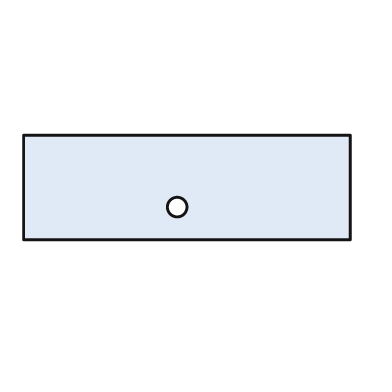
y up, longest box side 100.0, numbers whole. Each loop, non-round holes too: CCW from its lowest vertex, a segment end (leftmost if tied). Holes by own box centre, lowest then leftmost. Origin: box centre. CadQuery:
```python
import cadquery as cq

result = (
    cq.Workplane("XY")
    .moveTo(-50.0, -16.0)
    .lineTo(50.0, -16.0)
    .lineTo(50.0, 16.0)
    .lineTo(-50.0, 16.0)
    .close()
    .moveTo(-3.0, -6.0)
    .circle(3.0)
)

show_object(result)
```